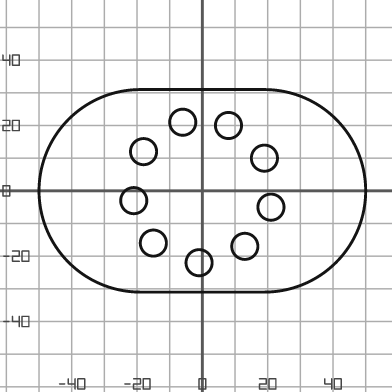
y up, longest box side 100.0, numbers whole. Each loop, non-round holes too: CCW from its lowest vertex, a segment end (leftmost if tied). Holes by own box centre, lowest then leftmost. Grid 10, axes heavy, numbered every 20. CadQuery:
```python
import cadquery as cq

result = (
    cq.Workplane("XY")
    .moveTo(-19.0, -31.0)
    .lineTo(19.0, -31.0)
    .threePointArc((50.0, 0.0), (19.0, 31.0))
    .lineTo(-19.0, 31.0)
    .threePointArc((-50.0, 0.0), (-19.0, -31.0))
    .close()
    .moveTo(-1.0, -22.0)
    .circle(4.0)
    .moveTo(13.0, -17.0)
    .circle(4.0)
    .moveTo(-15.0, -16.0)
    .circle(4.0)
    .moveTo(21.0, -5.0)
    .circle(4.0)
    .moveTo(-21.0, -3.0)
    .circle(4.0)
    .moveTo(19.0, 10.0)
    .circle(4.0)
    .moveTo(-18.0, 12.0)
    .circle(4.0)
    .moveTo(8.0, 20.0)
    .circle(4.0)
    .moveTo(-6.0, 21.0)
    .circle(4.0)
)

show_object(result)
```